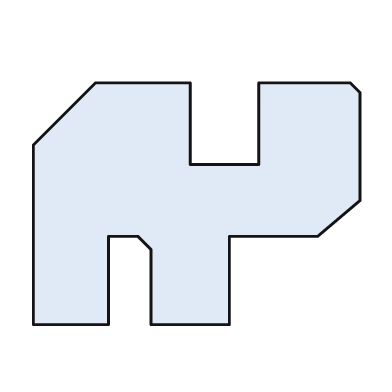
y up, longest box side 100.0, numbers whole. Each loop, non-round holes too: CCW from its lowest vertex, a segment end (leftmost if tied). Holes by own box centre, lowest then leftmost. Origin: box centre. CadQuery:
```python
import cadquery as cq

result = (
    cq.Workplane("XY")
    .moveTo(-50.0, -37.0)
    .lineTo(-27.0, -37.0)
    .lineTo(-27.0, -10.0)
    .lineTo(-18.0, -10.0)
    .lineTo(-14.0, -14.0)
    .lineTo(-14.0, -37.0)
    .lineTo(10.0, -37.0)
    .lineTo(10.0, -10.0)
    .lineTo(37.0, -10.0)
    .lineTo(50.0, 1.0)
    .lineTo(50.0, 34.0)
    .lineTo(47.0, 37.0)
    .lineTo(19.0, 37.0)
    .lineTo(19.0, 12.0)
    .lineTo(-2.0, 12.0)
    .lineTo(-2.0, 37.0)
    .lineTo(-31.0, 37.0)
    .lineTo(-50.0, 18.0)
    .close()
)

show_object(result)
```